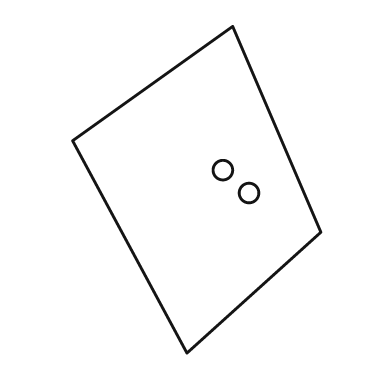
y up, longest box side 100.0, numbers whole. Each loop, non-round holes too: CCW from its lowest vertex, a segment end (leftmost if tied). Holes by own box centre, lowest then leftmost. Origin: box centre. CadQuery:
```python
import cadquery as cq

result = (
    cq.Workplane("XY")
    .moveTo(-3.0, -50.0)
    .lineTo(38.0, -13.0)
    .lineTo(11.0, 50.0)
    .lineTo(-38.0, 15.0)
    .close()
    .moveTo(16.0, -1.0)
    .circle(3.0)
    .moveTo(8.0, 6.0)
    .circle(3.0)
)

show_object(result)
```